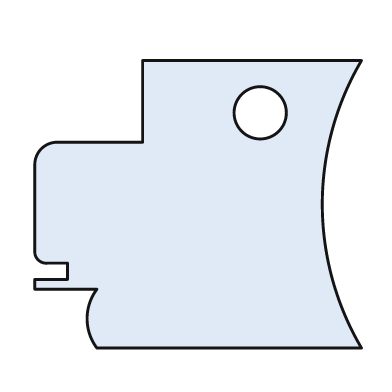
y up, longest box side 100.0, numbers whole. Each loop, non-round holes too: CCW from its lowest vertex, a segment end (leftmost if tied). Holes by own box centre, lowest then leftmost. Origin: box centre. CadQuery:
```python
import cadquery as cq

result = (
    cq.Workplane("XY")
    .moveTo(-31.0, -44.0)
    .lineTo(50.0, -44.0)
    .threePointArc((38.0, 0.0), (50.0, 44.0))
    .lineTo(-17.0, 44.0)
    .lineTo(-17.0, 19.0)
    .lineTo(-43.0, 19.0)
    .threePointArc((-48.0, 17.0), (-50.0, 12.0))
    .lineTo(-50.0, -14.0)
    .threePointArc((-49.0, -17.0), (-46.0, -18.0))
    .lineTo(-40.0, -18.0)
    .lineTo(-40.0, -23.0)
    .lineTo(-50.0, -23.0)
    .lineTo(-50.0, -26.0)
    .lineTo(-31.0, -26.0)
    .threePointArc((-34.0, -35.0), (-31.0, -44.0))
    .close()
    .moveTo(19.0, 28.0)
    .circle(8.0)
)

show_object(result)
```